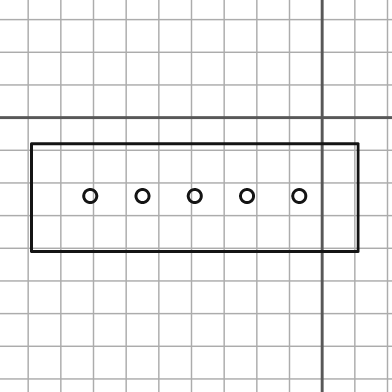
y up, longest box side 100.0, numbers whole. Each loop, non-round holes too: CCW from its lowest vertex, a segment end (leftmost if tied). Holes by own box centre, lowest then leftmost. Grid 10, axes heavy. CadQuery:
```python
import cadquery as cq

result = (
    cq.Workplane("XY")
    .moveTo(-89.0, -41.0)
    .lineTo(11.0, -41.0)
    .lineTo(11.0, -8.0)
    .lineTo(-89.0, -8.0)
    .close()
    .moveTo(-71.0, -24.0)
    .circle(2.0)
    .moveTo(-55.0, -24.0)
    .circle(2.0)
    .moveTo(-39.0, -24.0)
    .circle(2.0)
    .moveTo(-23.0, -24.0)
    .circle(2.0)
    .moveTo(-7.0, -24.0)
    .circle(2.0)
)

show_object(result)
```